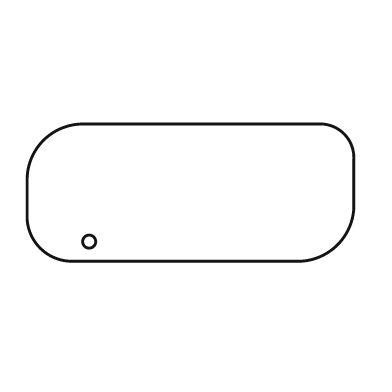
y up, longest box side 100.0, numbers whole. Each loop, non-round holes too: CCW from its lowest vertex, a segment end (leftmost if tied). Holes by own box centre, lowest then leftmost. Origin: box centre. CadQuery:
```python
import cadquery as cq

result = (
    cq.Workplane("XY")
    .moveTo(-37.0, -21.0)
    .lineTo(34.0, -21.0)
    .threePointArc((45.0, -16.0), (50.0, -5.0))
    .lineTo(50.0, 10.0)
    .threePointArc((47.0, 18.0), (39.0, 21.0))
    .lineTo(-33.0, 21.0)
    .threePointArc((-45.0, 16.0), (-50.0, 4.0))
    .lineTo(-50.0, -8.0)
    .threePointArc((-46.0, -17.0), (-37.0, -21.0))
    .close()
    .moveTo(-31.0, -15.0)
    .circle(2.0)
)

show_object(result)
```